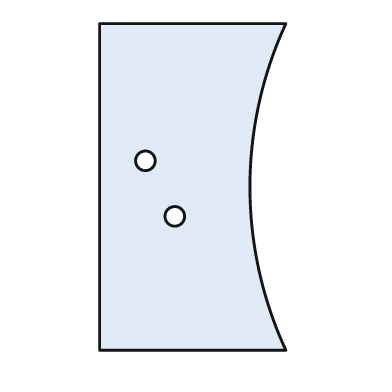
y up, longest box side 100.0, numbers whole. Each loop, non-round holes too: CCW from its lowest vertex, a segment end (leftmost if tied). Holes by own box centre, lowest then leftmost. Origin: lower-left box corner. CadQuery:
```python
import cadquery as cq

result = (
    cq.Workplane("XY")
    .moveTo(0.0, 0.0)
    .lineTo(57.0, 0.0)
    .threePointArc((46.0, 50.0), (57.0, 100.0))
    .lineTo(0.0, 100.0)
    .close()
    .moveTo(23.0, 41.0)
    .circle(3.0)
    .moveTo(14.0, 58.0)
    .circle(3.0)
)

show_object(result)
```